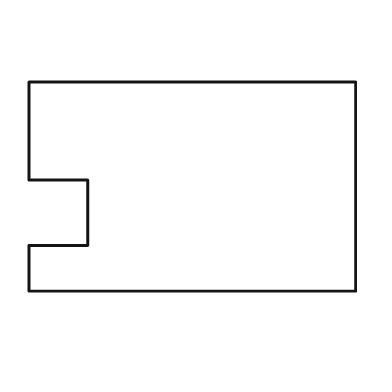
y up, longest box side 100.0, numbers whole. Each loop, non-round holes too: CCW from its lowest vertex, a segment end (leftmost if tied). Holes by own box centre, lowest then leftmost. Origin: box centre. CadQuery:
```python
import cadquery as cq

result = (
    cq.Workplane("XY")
    .moveTo(-50.0, -32.0)
    .lineTo(50.0, -32.0)
    .lineTo(50.0, 32.0)
    .lineTo(-50.0, 32.0)
    .lineTo(-50.0, 2.0)
    .lineTo(-32.0, 2.0)
    .lineTo(-32.0, -18.0)
    .lineTo(-50.0, -18.0)
    .close()
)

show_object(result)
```